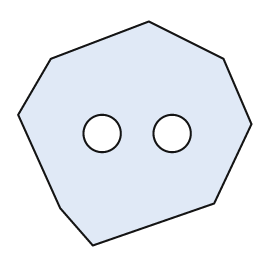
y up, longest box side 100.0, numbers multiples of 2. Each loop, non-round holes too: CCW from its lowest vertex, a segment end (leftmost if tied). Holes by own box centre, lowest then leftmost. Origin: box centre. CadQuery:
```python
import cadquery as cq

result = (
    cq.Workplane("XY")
    .moveTo(-18.0, -48.0)
    .lineTo(34.0, -30.0)
    .lineTo(50.0, 4.0)
    .lineTo(38.0, 32.0)
    .lineTo(6.0, 48.0)
    .lineTo(-36.0, 32.0)
    .lineTo(-50.0, 8.0)
    .lineTo(-32.0, -32.0)
    .close()
    .moveTo(-14.0, 0.0)
    .circle(8.0)
    .moveTo(16.0, 0.0)
    .circle(8.0)
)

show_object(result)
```